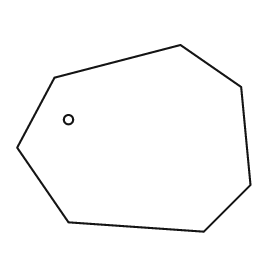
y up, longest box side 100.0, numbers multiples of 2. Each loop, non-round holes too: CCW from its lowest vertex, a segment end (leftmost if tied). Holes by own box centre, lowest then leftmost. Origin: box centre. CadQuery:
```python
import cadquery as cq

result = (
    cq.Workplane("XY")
    .moveTo(30.0, -40.0)
    .lineTo(50.0, -20.0)
    .lineTo(46.0, 22.0)
    .lineTo(20.0, 40.0)
    .lineTo(-34.0, 26.0)
    .lineTo(-50.0, -4.0)
    .lineTo(-28.0, -36.0)
    .close()
    .moveTo(-28.0, 8.0)
    .circle(2.0)
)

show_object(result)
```